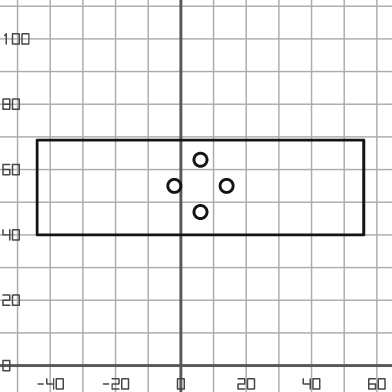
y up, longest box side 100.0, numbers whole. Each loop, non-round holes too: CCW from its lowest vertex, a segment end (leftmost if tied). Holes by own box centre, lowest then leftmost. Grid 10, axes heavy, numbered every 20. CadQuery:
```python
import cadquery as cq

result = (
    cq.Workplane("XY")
    .moveTo(-44.0, 40.0)
    .lineTo(56.0, 40.0)
    .lineTo(56.0, 69.0)
    .lineTo(-44.0, 69.0)
    .close()
    .moveTo(6.0, 47.0)
    .circle(2.0)
    .moveTo(-2.0, 55.0)
    .circle(2.0)
    .moveTo(14.0, 55.0)
    .circle(2.0)
    .moveTo(6.0, 63.0)
    .circle(2.0)
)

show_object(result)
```